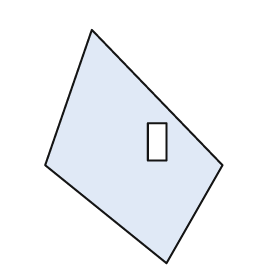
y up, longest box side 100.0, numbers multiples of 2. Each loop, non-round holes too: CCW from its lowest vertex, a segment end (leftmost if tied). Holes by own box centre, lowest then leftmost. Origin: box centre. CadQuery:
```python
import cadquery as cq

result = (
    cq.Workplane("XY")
    .moveTo(14.0, -50.0)
    .lineTo(38.0, -8.0)
    .lineTo(-18.0, 50.0)
    .lineTo(-38.0, -8.0)
    .close()
    .moveTo(6.0, -6.0)
    .lineTo(14.0, -6.0)
    .lineTo(14.0, 10.0)
    .lineTo(6.0, 10.0)
    .close()
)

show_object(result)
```